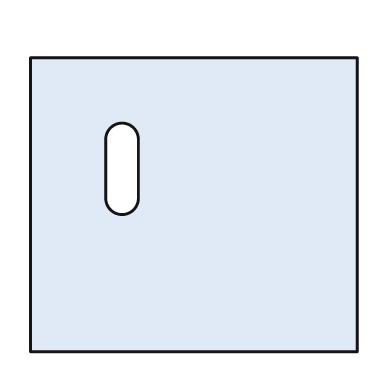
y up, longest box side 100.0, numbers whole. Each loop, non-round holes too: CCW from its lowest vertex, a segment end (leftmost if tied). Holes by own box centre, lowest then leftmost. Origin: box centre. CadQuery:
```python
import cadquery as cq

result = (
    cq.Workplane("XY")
    .moveTo(-50.0, -45.0)
    .lineTo(50.0, -45.0)
    .lineTo(50.0, 45.0)
    .lineTo(-50.0, 45.0)
    .close()
    .moveTo(-27.0, 2.0)
    .threePointArc((-22.0, -3.0), (-17.0, 2.0))
    .lineTo(-17.0, 20.0)
    .threePointArc((-22.0, 25.0), (-27.0, 20.0))
    .close()
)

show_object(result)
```